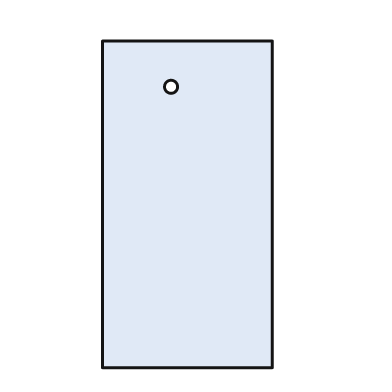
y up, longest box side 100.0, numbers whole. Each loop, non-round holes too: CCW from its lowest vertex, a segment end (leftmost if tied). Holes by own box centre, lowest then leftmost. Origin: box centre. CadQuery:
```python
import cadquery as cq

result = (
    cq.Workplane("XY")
    .moveTo(-26.0, -50.0)
    .lineTo(26.0, -50.0)
    .lineTo(26.0, 50.0)
    .lineTo(-26.0, 50.0)
    .close()
    .moveTo(-5.0, 36.0)
    .circle(2.0)
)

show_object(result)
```